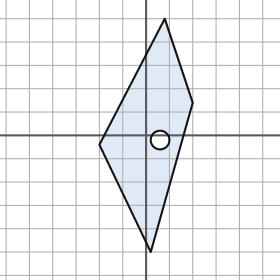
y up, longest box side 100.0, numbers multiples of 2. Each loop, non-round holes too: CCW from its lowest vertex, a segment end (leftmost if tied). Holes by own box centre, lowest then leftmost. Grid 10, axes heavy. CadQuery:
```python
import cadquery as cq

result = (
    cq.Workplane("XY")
    .moveTo(2.0, -50.0)
    .lineTo(20.0, 14.0)
    .lineTo(8.0, 50.0)
    .lineTo(-20.0, -4.0)
    .close()
    .moveTo(6.0, -2.0)
    .circle(4.0)
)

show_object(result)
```